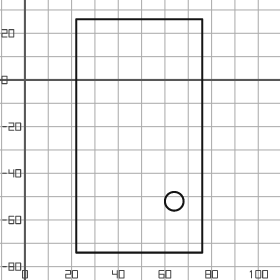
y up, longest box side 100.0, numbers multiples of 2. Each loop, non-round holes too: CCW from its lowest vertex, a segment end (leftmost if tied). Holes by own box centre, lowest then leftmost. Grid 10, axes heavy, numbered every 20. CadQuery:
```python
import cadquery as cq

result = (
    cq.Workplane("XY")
    .moveTo(22.0, -74.0)
    .lineTo(76.0, -74.0)
    .lineTo(76.0, 26.0)
    .lineTo(22.0, 26.0)
    .close()
    .moveTo(64.0, -52.0)
    .circle(4.0)
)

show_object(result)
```